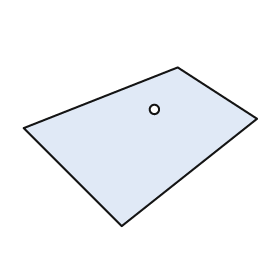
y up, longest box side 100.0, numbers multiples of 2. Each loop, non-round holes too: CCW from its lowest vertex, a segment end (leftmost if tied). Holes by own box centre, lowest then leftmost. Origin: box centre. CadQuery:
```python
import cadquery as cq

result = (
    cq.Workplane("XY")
    .moveTo(-8.0, -34.0)
    .lineTo(50.0, 12.0)
    .lineTo(16.0, 34.0)
    .lineTo(-50.0, 8.0)
    .close()
    .moveTo(6.0, 16.0)
    .circle(2.0)
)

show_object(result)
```